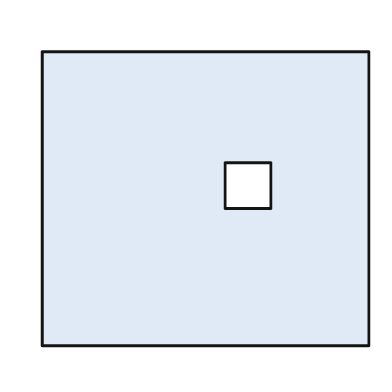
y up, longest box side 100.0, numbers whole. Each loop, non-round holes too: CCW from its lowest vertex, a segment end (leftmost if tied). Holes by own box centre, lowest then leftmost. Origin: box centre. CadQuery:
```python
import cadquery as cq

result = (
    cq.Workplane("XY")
    .moveTo(-50.0, -45.0)
    .lineTo(50.0, -45.0)
    .lineTo(50.0, 45.0)
    .lineTo(-50.0, 45.0)
    .close()
    .moveTo(6.0, -3.0)
    .lineTo(20.0, -3.0)
    .lineTo(20.0, 11.0)
    .lineTo(6.0, 11.0)
    .close()
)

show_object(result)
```